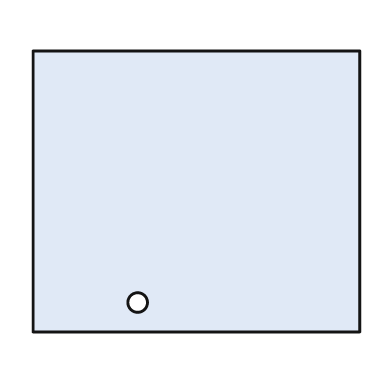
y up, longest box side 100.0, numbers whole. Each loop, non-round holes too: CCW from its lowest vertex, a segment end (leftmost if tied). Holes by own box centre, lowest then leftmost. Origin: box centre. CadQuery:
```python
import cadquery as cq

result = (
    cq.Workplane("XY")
    .moveTo(-50.0, -43.0)
    .lineTo(50.0, -43.0)
    .lineTo(50.0, 43.0)
    .lineTo(-50.0, 43.0)
    .close()
    .moveTo(-18.0, -34.0)
    .circle(3.0)
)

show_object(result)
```